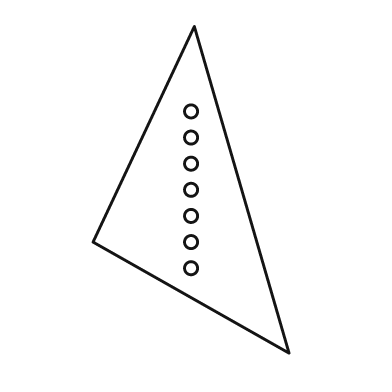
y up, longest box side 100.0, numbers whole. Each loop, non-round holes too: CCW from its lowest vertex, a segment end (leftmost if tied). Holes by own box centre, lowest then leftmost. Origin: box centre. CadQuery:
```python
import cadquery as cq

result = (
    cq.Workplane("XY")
    .moveTo(30.0, -50.0)
    .lineTo(1.0, 50.0)
    .lineTo(-30.0, -16.0)
    .close()
    .moveTo(0.0, -24.0)
    .circle(2.0)
    .moveTo(0.0, -16.0)
    .circle(2.0)
    .moveTo(0.0, -8.0)
    .circle(2.0)
    .moveTo(0.0, 0.0)
    .circle(2.0)
    .moveTo(0.0, 8.0)
    .circle(2.0)
    .moveTo(0.0, 16.0)
    .circle(2.0)
    .moveTo(0.0, 24.0)
    .circle(2.0)
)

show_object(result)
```